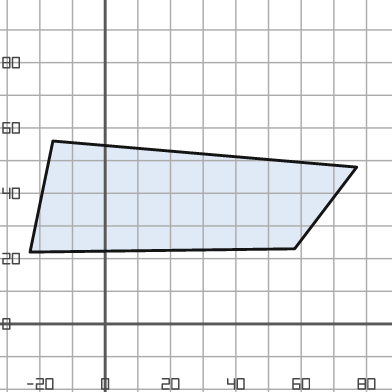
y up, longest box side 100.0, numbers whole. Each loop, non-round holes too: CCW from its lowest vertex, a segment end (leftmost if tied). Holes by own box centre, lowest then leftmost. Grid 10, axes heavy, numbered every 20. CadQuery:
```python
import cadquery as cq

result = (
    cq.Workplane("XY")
    .moveTo(-23.0, 22.0)
    .lineTo(58.0, 23.0)
    .lineTo(77.0, 48.0)
    .lineTo(-16.0, 56.0)
    .close()
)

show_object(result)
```